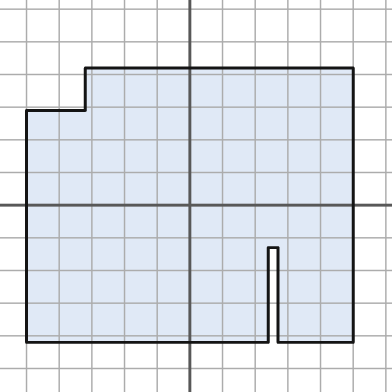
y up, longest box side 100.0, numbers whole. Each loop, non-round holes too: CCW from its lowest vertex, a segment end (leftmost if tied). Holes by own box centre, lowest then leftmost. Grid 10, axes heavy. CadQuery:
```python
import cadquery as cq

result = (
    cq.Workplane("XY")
    .moveTo(-50.0, -42.0)
    .lineTo(24.0, -42.0)
    .lineTo(24.0, -13.0)
    .lineTo(27.0, -13.0)
    .lineTo(27.0, -42.0)
    .lineTo(50.0, -42.0)
    .lineTo(50.0, 42.0)
    .lineTo(-32.0, 42.0)
    .lineTo(-32.0, 29.0)
    .lineTo(-50.0, 29.0)
    .close()
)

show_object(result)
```